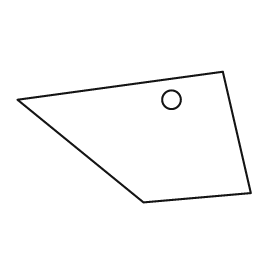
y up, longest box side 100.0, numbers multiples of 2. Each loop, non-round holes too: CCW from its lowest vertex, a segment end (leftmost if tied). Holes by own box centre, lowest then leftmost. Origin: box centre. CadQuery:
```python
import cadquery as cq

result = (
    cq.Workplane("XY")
    .moveTo(4.0, -28.0)
    .lineTo(50.0, -24.0)
    .lineTo(38.0, 28.0)
    .lineTo(-50.0, 16.0)
    .close()
    .moveTo(16.0, 16.0)
    .circle(4.0)
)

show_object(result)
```